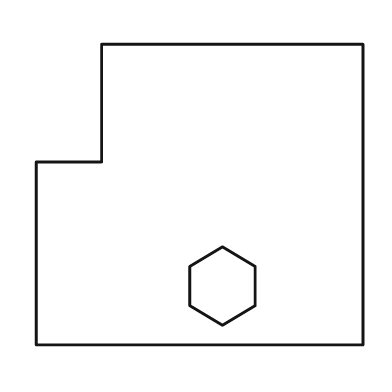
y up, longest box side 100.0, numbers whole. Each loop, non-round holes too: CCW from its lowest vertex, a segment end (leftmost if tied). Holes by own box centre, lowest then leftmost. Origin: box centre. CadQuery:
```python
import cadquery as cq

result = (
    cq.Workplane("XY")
    .moveTo(-50.0, -46.0)
    .lineTo(50.0, -46.0)
    .lineTo(50.0, 46.0)
    .lineTo(-30.0, 46.0)
    .lineTo(-30.0, 10.0)
    .lineTo(-50.0, 10.0)
    .close()
    .moveTo(7.0, -40.0)
    .lineTo(17.0, -34.0)
    .lineTo(17.0, -22.0)
    .lineTo(7.0, -16.0)
    .lineTo(-3.0, -22.0)
    .lineTo(-3.0, -34.0)
    .close()
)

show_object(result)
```